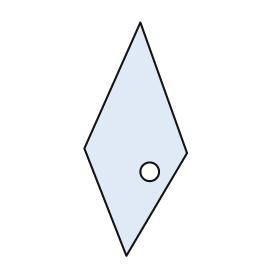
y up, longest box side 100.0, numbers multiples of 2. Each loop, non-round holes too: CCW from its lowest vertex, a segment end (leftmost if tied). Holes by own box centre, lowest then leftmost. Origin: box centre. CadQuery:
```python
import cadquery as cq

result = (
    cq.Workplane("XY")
    .moveTo(-4.0, -50.0)
    .lineTo(22.0, -6.0)
    .lineTo(2.0, 50.0)
    .lineTo(-22.0, -4.0)
    .close()
    .moveTo(6.0, -14.0)
    .circle(4.0)
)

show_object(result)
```